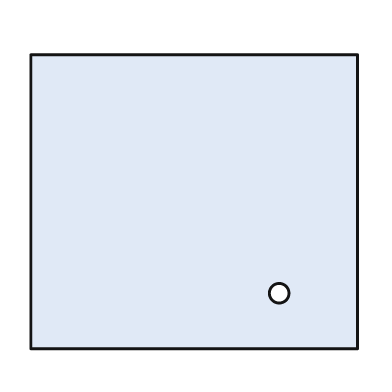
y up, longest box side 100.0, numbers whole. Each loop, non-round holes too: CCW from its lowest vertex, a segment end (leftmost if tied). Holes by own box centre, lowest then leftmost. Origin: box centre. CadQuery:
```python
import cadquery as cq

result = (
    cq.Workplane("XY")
    .moveTo(-50.0, -45.0)
    .lineTo(50.0, -45.0)
    .lineTo(50.0, 45.0)
    .lineTo(-50.0, 45.0)
    .close()
    .moveTo(26.0, -28.0)
    .circle(3.0)
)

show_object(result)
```